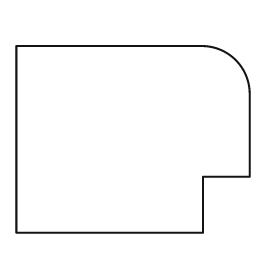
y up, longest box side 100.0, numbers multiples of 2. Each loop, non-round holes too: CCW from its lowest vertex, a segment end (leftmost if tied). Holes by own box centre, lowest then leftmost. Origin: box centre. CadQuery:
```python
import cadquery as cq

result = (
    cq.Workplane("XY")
    .moveTo(-50.0, -40.0)
    .lineTo(30.0, -40.0)
    .lineTo(30.0, -16.0)
    .lineTo(50.0, -16.0)
    .lineTo(50.0, 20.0)
    .threePointArc((44.0, 34.0), (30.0, 40.0))
    .lineTo(-50.0, 40.0)
    .close()
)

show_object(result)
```